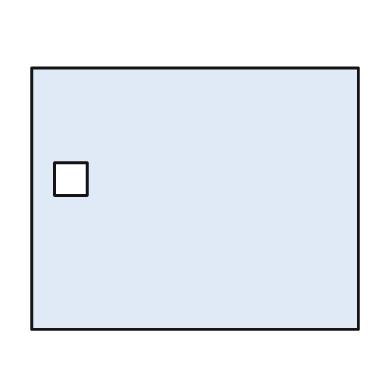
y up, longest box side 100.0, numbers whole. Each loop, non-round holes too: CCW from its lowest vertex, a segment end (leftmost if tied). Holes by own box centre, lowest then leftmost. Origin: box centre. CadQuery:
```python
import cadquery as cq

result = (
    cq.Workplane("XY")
    .moveTo(-50.0, -40.0)
    .lineTo(50.0, -40.0)
    .lineTo(50.0, 40.0)
    .lineTo(-50.0, 40.0)
    .close()
    .moveTo(-43.0, 1.0)
    .lineTo(-33.0, 1.0)
    .lineTo(-33.0, 11.0)
    .lineTo(-43.0, 11.0)
    .close()
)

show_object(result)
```